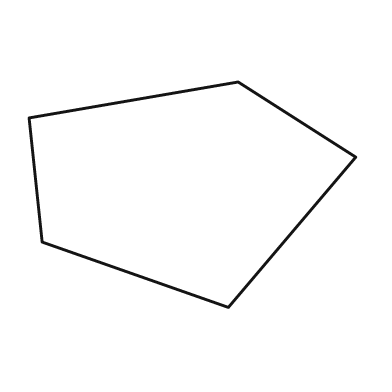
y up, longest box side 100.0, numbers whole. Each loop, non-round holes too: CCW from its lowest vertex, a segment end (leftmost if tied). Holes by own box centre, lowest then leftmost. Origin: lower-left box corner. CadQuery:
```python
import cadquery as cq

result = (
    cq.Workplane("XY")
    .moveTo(61.0, 0.0)
    .lineTo(100.0, 46.0)
    .lineTo(64.0, 69.0)
    .lineTo(0.0, 58.0)
    .lineTo(4.0, 20.0)
    .close()
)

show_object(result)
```